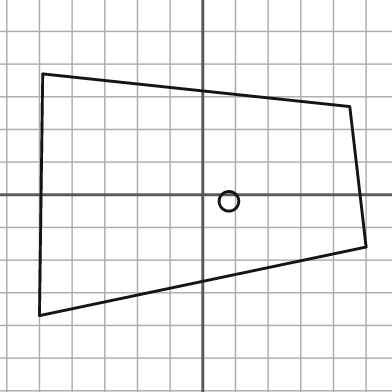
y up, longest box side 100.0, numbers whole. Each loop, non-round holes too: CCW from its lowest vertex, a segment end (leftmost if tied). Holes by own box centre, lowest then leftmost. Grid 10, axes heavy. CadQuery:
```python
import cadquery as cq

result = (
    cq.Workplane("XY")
    .moveTo(-50.0, -37.0)
    .lineTo(50.0, -16.0)
    .lineTo(45.0, 27.0)
    .lineTo(-49.0, 37.0)
    .close()
    .moveTo(8.0, -2.0)
    .circle(3.0)
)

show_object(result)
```